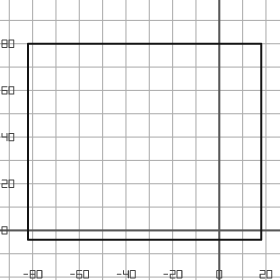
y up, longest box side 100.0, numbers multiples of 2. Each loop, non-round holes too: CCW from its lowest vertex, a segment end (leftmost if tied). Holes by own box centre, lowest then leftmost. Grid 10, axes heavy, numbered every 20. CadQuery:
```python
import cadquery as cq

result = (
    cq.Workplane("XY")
    .moveTo(-82.0, -4.0)
    .lineTo(18.0, -4.0)
    .lineTo(18.0, 80.0)
    .lineTo(-82.0, 80.0)
    .close()
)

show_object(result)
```